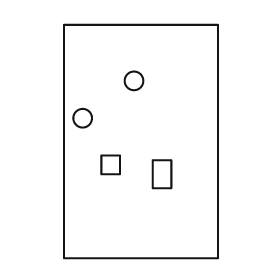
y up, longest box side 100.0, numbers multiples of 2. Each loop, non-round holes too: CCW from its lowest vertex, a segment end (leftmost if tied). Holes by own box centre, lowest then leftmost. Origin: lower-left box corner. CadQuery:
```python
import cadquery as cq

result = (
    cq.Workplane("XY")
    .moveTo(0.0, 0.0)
    .lineTo(66.0, 0.0)
    .lineTo(66.0, 100.0)
    .lineTo(0.0, 100.0)
    .close()
    .moveTo(38.0, 30.0)
    .lineTo(46.0, 30.0)
    .lineTo(46.0, 42.0)
    .lineTo(38.0, 42.0)
    .close()
    .moveTo(16.0, 36.0)
    .lineTo(24.0, 36.0)
    .lineTo(24.0, 44.0)
    .lineTo(16.0, 44.0)
    .close()
    .moveTo(8.0, 60.0)
    .circle(4.0)
    .moveTo(30.0, 76.0)
    .circle(4.0)
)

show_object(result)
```